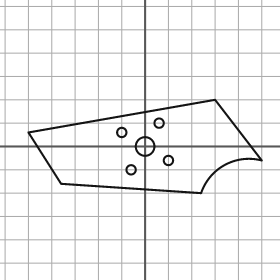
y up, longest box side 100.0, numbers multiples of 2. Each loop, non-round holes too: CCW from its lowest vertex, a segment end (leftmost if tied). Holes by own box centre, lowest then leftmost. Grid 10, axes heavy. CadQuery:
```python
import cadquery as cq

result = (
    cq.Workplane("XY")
    .moveTo(24.0, -20.0)
    .threePointArc((34.0, -8.0), (50.0, -6.0))
    .lineTo(30.0, 20.0)
    .lineTo(-50.0, 6.0)
    .lineTo(-36.0, -16.0)
    .close()
    .moveTo(-6.0, -10.0)
    .circle(2.0)
    .moveTo(10.0, -6.0)
    .circle(2.0)
    .moveTo(0.0, 0.0)
    .circle(4.0)
    .moveTo(-10.0, 6.0)
    .circle(2.0)
    .moveTo(6.0, 10.0)
    .circle(2.0)
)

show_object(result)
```